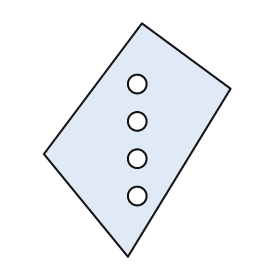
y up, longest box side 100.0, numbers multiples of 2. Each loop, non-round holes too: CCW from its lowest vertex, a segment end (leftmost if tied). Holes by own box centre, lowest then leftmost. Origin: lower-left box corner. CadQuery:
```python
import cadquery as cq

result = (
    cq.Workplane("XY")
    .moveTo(36.0, 0.0)
    .lineTo(80.0, 72.0)
    .lineTo(42.0, 100.0)
    .lineTo(0.0, 44.0)
    .close()
    .moveTo(40.0, 26.0)
    .circle(4.0)
    .moveTo(40.0, 42.0)
    .circle(4.0)
    .moveTo(40.0, 58.0)
    .circle(4.0)
    .moveTo(40.0, 74.0)
    .circle(4.0)
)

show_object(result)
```